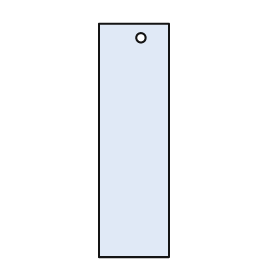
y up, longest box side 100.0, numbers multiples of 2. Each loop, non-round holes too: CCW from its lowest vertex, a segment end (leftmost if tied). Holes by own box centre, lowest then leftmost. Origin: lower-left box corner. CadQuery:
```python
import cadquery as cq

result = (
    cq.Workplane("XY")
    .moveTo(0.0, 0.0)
    .lineTo(30.0, 0.0)
    .lineTo(30.0, 100.0)
    .lineTo(0.0, 100.0)
    .close()
    .moveTo(18.0, 94.0)
    .circle(2.0)
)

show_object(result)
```